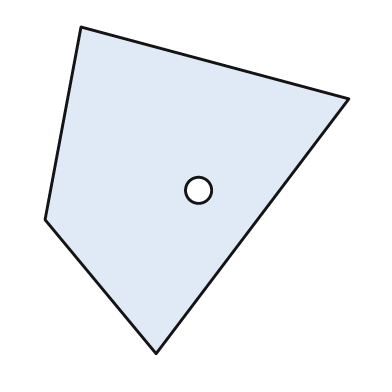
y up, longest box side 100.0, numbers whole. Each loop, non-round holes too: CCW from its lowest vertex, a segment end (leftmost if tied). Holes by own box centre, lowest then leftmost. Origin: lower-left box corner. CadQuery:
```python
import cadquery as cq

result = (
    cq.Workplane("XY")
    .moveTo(34.0, 0.0)
    .lineTo(93.0, 78.0)
    .lineTo(11.0, 100.0)
    .lineTo(0.0, 41.0)
    .close()
    .moveTo(47.0, 50.0)
    .circle(4.0)
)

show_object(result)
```